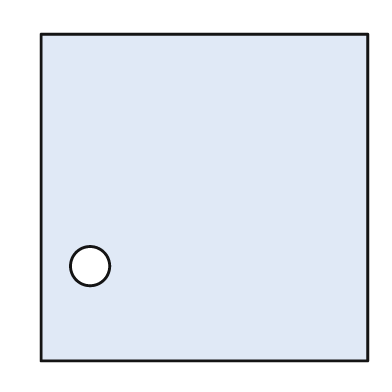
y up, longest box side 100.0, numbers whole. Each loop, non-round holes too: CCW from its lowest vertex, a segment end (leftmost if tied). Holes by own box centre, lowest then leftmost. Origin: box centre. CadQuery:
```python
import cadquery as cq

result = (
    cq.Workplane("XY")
    .moveTo(-50.0, -50.0)
    .lineTo(50.0, -50.0)
    .lineTo(50.0, 50.0)
    .lineTo(-50.0, 50.0)
    .close()
    .moveTo(-35.0, -21.0)
    .circle(6.0)
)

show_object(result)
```